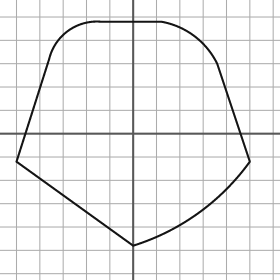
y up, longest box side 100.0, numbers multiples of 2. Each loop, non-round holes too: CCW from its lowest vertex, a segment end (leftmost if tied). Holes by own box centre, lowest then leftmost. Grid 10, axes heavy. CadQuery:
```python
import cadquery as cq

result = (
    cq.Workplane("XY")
    .moveTo(0.0, -48.0)
    .threePointArc((28.0, -34.0), (50.0, -12.0))
    .lineTo(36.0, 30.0)
    .threePointArc((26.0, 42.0), (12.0, 48.0))
    .lineTo(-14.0, 48.0)
    .threePointArc((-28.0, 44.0), (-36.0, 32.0))
    .lineTo(-50.0, -12.0)
    .close()
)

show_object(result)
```